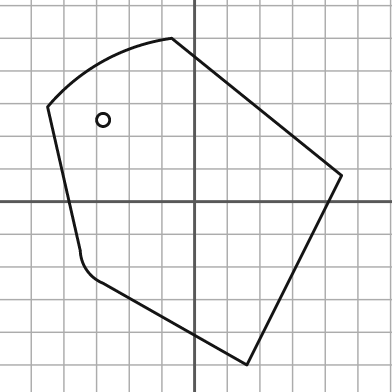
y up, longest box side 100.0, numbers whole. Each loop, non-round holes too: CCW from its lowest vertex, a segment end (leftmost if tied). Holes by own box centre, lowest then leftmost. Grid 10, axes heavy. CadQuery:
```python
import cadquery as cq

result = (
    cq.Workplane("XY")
    .moveTo(16.0, -50.0)
    .lineTo(45.0, 8.0)
    .lineTo(-7.0, 50.0)
    .threePointArc((-28.0, 43.0), (-45.0, 29.0))
    .lineTo(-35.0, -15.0)
    .threePointArc((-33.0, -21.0), (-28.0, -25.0))
    .close()
    .moveTo(-28.0, 25.0)
    .circle(2.0)
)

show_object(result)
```